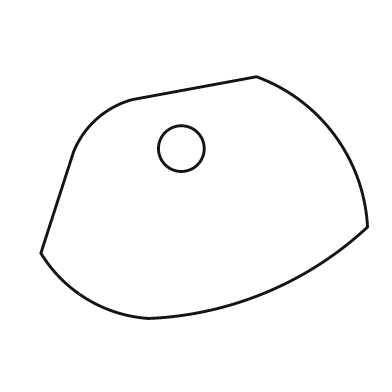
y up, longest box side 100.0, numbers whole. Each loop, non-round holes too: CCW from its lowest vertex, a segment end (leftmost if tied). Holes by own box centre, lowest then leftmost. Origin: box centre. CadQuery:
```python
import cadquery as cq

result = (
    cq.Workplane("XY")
    .moveTo(-17.0, -37.0)
    .threePointArc((19.0, -29.0), (50.0, -9.0))
    .threePointArc((40.0, 19.0), (16.0, 37.0))
    .lineTo(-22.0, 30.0)
    .threePointArc((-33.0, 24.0), (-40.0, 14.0))
    .lineTo(-50.0, -17.0)
    .threePointArc((-36.0, -31.0), (-17.0, -37.0))
    .close()
    .moveTo(-7.0, 15.0)
    .circle(7.0)
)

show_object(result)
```